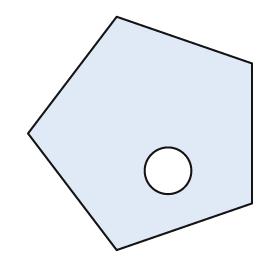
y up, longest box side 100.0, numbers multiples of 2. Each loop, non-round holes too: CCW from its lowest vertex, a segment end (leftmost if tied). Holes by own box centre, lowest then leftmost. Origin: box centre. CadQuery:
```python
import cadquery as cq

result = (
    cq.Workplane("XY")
    .moveTo(-10.0, -50.0)
    .lineTo(48.0, -30.0)
    .lineTo(48.0, 30.0)
    .lineTo(-10.0, 50.0)
    .lineTo(-48.0, 0.0)
    .close()
    .moveTo(12.0, -16.0)
    .circle(10.0)
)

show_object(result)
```